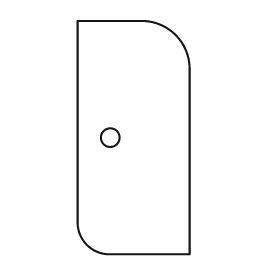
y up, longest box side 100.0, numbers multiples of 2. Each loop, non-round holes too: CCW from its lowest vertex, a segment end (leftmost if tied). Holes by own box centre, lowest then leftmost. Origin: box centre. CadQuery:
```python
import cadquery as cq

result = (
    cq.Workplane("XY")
    .moveTo(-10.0, -50.0)
    .lineTo(24.0, -50.0)
    .lineTo(24.0, 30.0)
    .threePointArc((18.0, 44.0), (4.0, 50.0))
    .lineTo(-24.0, 50.0)
    .lineTo(-24.0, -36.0)
    .threePointArc((-20.0, -46.0), (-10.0, -50.0))
    .close()
    .moveTo(-10.0, 0.0)
    .circle(4.0)
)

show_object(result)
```